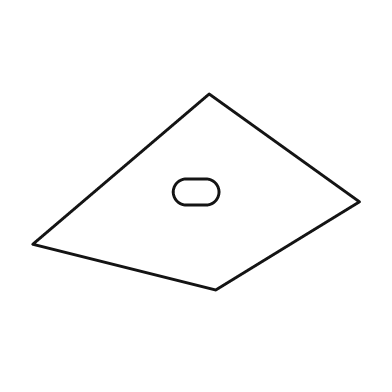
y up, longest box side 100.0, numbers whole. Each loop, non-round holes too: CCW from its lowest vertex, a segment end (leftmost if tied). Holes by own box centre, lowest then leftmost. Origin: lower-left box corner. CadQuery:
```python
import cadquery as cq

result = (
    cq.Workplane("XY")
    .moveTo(56.0, 0.0)
    .lineTo(100.0, 27.0)
    .lineTo(54.0, 60.0)
    .lineTo(0.0, 14.0)
    .close()
    .moveTo(47.0, 26.0)
    .lineTo(53.0, 26.0)
    .threePointArc((57.0, 30.0), (53.0, 34.0))
    .lineTo(47.0, 34.0)
    .threePointArc((43.0, 30.0), (47.0, 26.0))
    .close()
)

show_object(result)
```